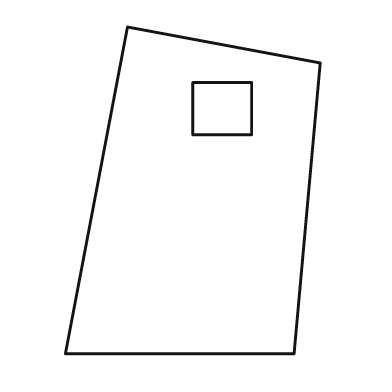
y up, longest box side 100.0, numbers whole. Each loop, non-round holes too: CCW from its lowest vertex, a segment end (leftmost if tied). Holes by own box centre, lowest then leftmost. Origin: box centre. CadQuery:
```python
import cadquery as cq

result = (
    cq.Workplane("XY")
    .moveTo(-39.0, -50.0)
    .lineTo(31.0, -50.0)
    .lineTo(39.0, 39.0)
    .lineTo(-20.0, 50.0)
    .close()
    .moveTo(0.0, 17.0)
    .lineTo(18.0, 17.0)
    .lineTo(18.0, 33.0)
    .lineTo(0.0, 33.0)
    .close()
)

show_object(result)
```